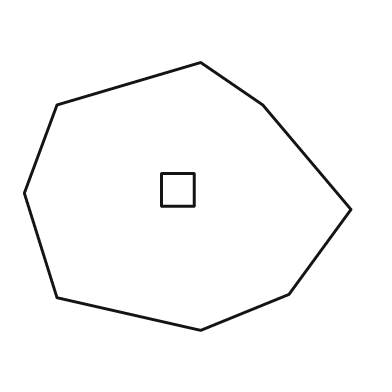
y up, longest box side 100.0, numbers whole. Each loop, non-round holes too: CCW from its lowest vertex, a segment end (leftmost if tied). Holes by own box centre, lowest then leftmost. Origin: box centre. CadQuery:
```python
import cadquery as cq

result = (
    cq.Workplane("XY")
    .moveTo(4.0, -41.0)
    .lineTo(31.0, -30.0)
    .lineTo(50.0, -4.0)
    .lineTo(23.0, 28.0)
    .lineTo(4.0, 41.0)
    .lineTo(-40.0, 28.0)
    .lineTo(-50.0, 1.0)
    .lineTo(-40.0, -31.0)
    .close()
    .moveTo(-8.0, -3.0)
    .lineTo(2.0, -3.0)
    .lineTo(2.0, 7.0)
    .lineTo(-8.0, 7.0)
    .close()
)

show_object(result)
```